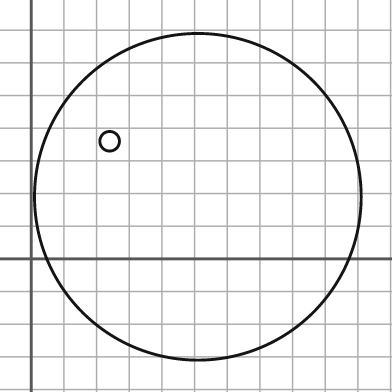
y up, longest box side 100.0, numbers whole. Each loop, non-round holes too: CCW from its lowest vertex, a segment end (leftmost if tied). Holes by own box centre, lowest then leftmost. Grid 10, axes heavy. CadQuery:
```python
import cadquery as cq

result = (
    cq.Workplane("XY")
    .moveTo(51.0, 19.0)
    .circle(50.0)
    .moveTo(24.0, 36.0)
    .circle(3.0)
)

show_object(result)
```